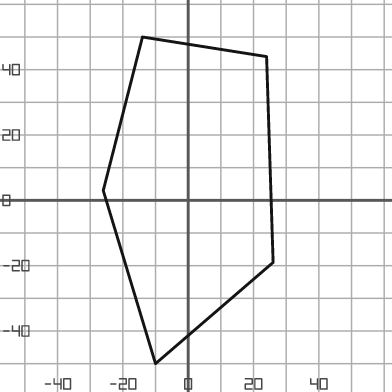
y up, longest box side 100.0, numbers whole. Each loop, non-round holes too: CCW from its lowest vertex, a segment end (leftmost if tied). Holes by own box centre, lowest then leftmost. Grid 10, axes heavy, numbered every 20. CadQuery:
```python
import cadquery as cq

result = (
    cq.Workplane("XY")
    .moveTo(-10.0, -50.0)
    .lineTo(26.0, -19.0)
    .lineTo(24.0, 44.0)
    .lineTo(-14.0, 50.0)
    .lineTo(-26.0, 3.0)
    .close()
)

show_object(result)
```